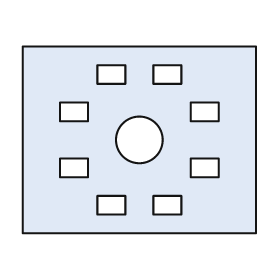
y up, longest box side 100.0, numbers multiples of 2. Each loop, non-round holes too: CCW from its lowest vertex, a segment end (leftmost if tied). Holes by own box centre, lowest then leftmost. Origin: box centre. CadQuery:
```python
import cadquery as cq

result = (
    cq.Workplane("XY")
    .moveTo(-50.0, -40.0)
    .lineTo(50.0, -40.0)
    .lineTo(50.0, 40.0)
    .lineTo(-50.0, 40.0)
    .close()
    .moveTo(-18.0, -32.0)
    .lineTo(-6.0, -32.0)
    .lineTo(-6.0, -24.0)
    .lineTo(-18.0, -24.0)
    .close()
    .moveTo(6.0, -32.0)
    .lineTo(18.0, -32.0)
    .lineTo(18.0, -24.0)
    .lineTo(6.0, -24.0)
    .close()
    .moveTo(-34.0, -16.0)
    .lineTo(-22.0, -16.0)
    .lineTo(-22.0, -8.0)
    .lineTo(-34.0, -8.0)
    .close()
    .moveTo(22.0, -16.0)
    .lineTo(34.0, -16.0)
    .lineTo(34.0, -8.0)
    .lineTo(22.0, -8.0)
    .close()
    .moveTo(0.0, 0.0)
    .circle(10.0)
    .moveTo(-34.0, 8.0)
    .lineTo(-22.0, 8.0)
    .lineTo(-22.0, 16.0)
    .lineTo(-34.0, 16.0)
    .close()
    .moveTo(22.0, 8.0)
    .lineTo(34.0, 8.0)
    .lineTo(34.0, 16.0)
    .lineTo(22.0, 16.0)
    .close()
    .moveTo(-18.0, 24.0)
    .lineTo(-6.0, 24.0)
    .lineTo(-6.0, 32.0)
    .lineTo(-18.0, 32.0)
    .close()
    .moveTo(6.0, 24.0)
    .lineTo(18.0, 24.0)
    .lineTo(18.0, 32.0)
    .lineTo(6.0, 32.0)
    .close()
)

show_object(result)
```